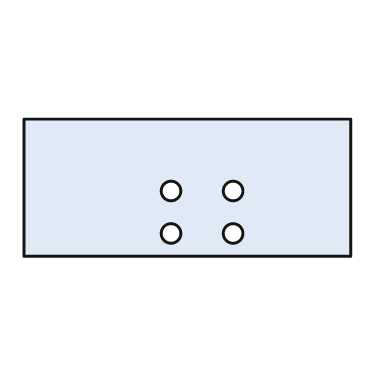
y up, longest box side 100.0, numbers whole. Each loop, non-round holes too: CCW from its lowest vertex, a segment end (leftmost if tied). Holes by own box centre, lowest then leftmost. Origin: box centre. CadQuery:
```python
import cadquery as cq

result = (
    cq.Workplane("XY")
    .moveTo(-50.0, -21.0)
    .lineTo(50.0, -21.0)
    .lineTo(50.0, 21.0)
    .lineTo(-50.0, 21.0)
    .close()
    .moveTo(-5.0, -14.0)
    .circle(3.0)
    .moveTo(14.0, -14.0)
    .circle(3.0)
    .moveTo(-5.0, -1.0)
    .circle(3.0)
    .moveTo(14.0, -1.0)
    .circle(3.0)
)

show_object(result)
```